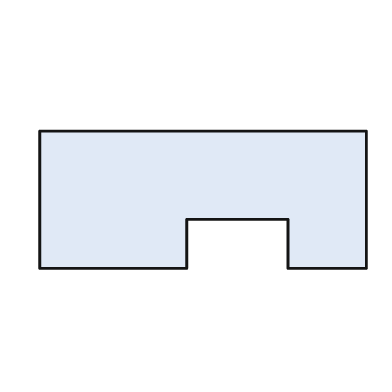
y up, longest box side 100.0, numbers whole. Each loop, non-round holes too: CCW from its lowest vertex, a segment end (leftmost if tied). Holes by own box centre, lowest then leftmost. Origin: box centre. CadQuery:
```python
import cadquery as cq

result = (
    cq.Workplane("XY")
    .moveTo(-50.0, -21.0)
    .lineTo(-5.0, -21.0)
    .lineTo(-5.0, -6.0)
    .lineTo(26.0, -6.0)
    .lineTo(26.0, -21.0)
    .lineTo(50.0, -21.0)
    .lineTo(50.0, 21.0)
    .lineTo(-50.0, 21.0)
    .close()
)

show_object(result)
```